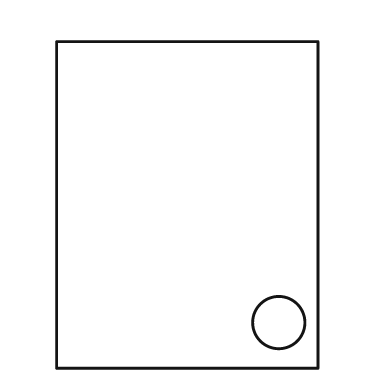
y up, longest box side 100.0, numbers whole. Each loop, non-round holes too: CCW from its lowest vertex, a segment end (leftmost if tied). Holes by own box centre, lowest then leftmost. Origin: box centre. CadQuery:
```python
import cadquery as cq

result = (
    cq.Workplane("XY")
    .moveTo(-40.0, -50.0)
    .lineTo(40.0, -50.0)
    .lineTo(40.0, 50.0)
    .lineTo(-40.0, 50.0)
    .close()
    .moveTo(28.0, -36.0)
    .circle(8.0)
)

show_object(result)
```